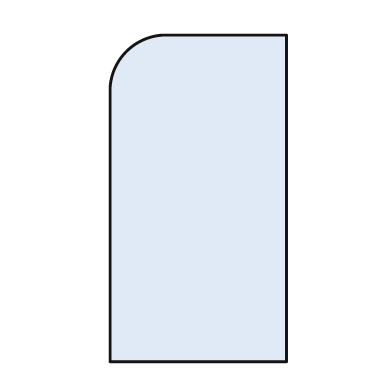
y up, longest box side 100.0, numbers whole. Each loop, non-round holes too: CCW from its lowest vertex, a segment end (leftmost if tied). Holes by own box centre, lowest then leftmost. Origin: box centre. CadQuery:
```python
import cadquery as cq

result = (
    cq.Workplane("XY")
    .moveTo(-27.0, -50.0)
    .lineTo(27.0, -50.0)
    .lineTo(27.0, 50.0)
    .lineTo(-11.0, 50.0)
    .threePointArc((-22.0, 45.0), (-27.0, 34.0))
    .close()
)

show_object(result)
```